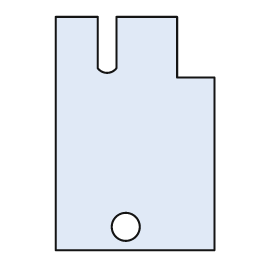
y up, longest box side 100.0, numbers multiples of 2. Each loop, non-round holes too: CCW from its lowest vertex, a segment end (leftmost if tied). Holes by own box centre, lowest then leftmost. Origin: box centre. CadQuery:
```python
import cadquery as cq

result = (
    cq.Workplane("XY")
    .moveTo(-34.0, -50.0)
    .lineTo(34.0, -50.0)
    .lineTo(34.0, 24.0)
    .lineTo(18.0, 24.0)
    .lineTo(18.0, 50.0)
    .lineTo(-8.0, 50.0)
    .lineTo(-8.0, 28.0)
    .threePointArc((-12.0, 26.0), (-16.0, 28.0))
    .lineTo(-16.0, 50.0)
    .lineTo(-34.0, 50.0)
    .close()
    .moveTo(-4.0, -40.0)
    .circle(6.0)
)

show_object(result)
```